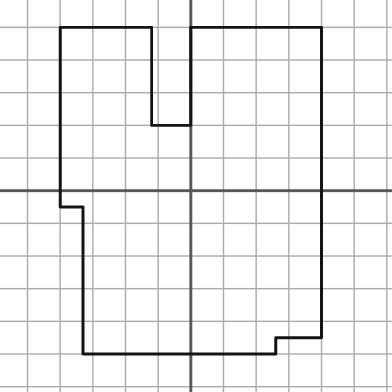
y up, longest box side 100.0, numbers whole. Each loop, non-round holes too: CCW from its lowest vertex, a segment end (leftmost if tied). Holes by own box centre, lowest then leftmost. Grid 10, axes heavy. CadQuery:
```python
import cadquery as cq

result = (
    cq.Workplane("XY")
    .moveTo(-33.0, -50.0)
    .lineTo(26.0, -50.0)
    .lineTo(26.0, -45.0)
    .lineTo(40.0, -45.0)
    .lineTo(40.0, 50.0)
    .lineTo(0.0, 50.0)
    .lineTo(0.0, 20.0)
    .lineTo(-12.0, 20.0)
    .lineTo(-12.0, 50.0)
    .lineTo(-40.0, 50.0)
    .lineTo(-40.0, -5.0)
    .lineTo(-33.0, -5.0)
    .close()
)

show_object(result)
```